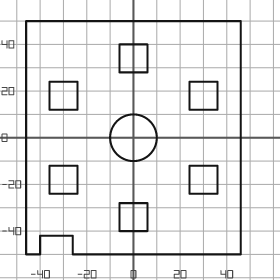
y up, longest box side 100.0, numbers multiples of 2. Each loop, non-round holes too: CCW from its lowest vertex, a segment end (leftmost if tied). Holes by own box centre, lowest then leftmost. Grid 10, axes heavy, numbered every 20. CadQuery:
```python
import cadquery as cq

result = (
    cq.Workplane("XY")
    .moveTo(-46.0, -50.0)
    .lineTo(-40.0, -50.0)
    .lineTo(-40.0, -42.0)
    .lineTo(-26.0, -42.0)
    .lineTo(-26.0, -50.0)
    .lineTo(46.0, -50.0)
    .lineTo(46.0, 50.0)
    .lineTo(-46.0, 50.0)
    .close()
    .moveTo(-6.0, -40.0)
    .lineTo(6.0, -40.0)
    .lineTo(6.0, -28.0)
    .lineTo(-6.0, -28.0)
    .close()
    .moveTo(-36.0, -24.0)
    .lineTo(-24.0, -24.0)
    .lineTo(-24.0, -12.0)
    .lineTo(-36.0, -12.0)
    .close()
    .moveTo(24.0, -24.0)
    .lineTo(36.0, -24.0)
    .lineTo(36.0, -12.0)
    .lineTo(24.0, -12.0)
    .close()
    .moveTo(0.0, 0.0)
    .circle(10.0)
    .moveTo(-36.0, 12.0)
    .lineTo(-24.0, 12.0)
    .lineTo(-24.0, 24.0)
    .lineTo(-36.0, 24.0)
    .close()
    .moveTo(24.0, 12.0)
    .lineTo(36.0, 12.0)
    .lineTo(36.0, 24.0)
    .lineTo(24.0, 24.0)
    .close()
    .moveTo(-6.0, 28.0)
    .lineTo(6.0, 28.0)
    .lineTo(6.0, 40.0)
    .lineTo(-6.0, 40.0)
    .close()
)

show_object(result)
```